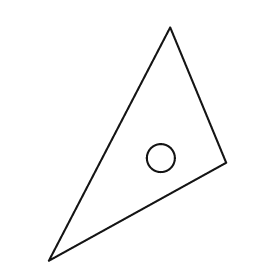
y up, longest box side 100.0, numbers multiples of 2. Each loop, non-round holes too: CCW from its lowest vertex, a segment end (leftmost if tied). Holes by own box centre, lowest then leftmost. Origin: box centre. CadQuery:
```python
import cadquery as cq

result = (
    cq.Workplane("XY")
    .moveTo(-38.0, -50.0)
    .lineTo(38.0, -8.0)
    .lineTo(14.0, 50.0)
    .close()
    .moveTo(10.0, -6.0)
    .circle(6.0)
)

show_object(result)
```